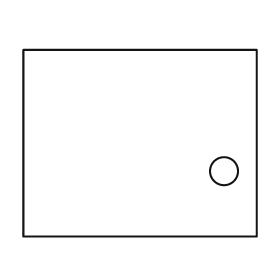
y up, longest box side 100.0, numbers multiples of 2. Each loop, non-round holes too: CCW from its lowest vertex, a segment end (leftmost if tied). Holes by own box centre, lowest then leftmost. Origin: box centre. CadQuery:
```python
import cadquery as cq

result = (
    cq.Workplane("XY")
    .moveTo(-50.0, -40.0)
    .lineTo(50.0, -40.0)
    .lineTo(50.0, 40.0)
    .lineTo(-50.0, 40.0)
    .close()
    .moveTo(36.0, -12.0)
    .circle(6.0)
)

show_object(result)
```